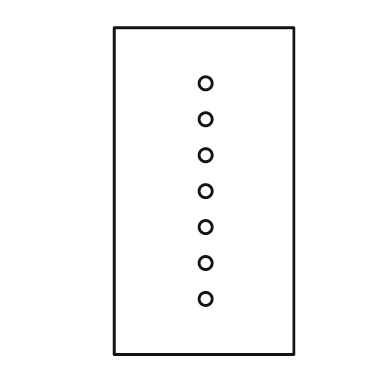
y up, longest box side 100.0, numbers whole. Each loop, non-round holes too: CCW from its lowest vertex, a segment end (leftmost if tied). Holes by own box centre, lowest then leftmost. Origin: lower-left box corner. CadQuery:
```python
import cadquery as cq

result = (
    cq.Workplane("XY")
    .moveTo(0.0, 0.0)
    .lineTo(55.0, 0.0)
    .lineTo(55.0, 100.0)
    .lineTo(0.0, 100.0)
    .close()
    .moveTo(28.0, 17.0)
    .circle(2.0)
    .moveTo(28.0, 28.0)
    .circle(2.0)
    .moveTo(28.0, 39.0)
    .circle(2.0)
    .moveTo(28.0, 50.0)
    .circle(2.0)
    .moveTo(28.0, 61.0)
    .circle(2.0)
    .moveTo(28.0, 72.0)
    .circle(2.0)
    .moveTo(28.0, 83.0)
    .circle(2.0)
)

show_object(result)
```